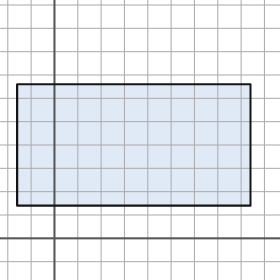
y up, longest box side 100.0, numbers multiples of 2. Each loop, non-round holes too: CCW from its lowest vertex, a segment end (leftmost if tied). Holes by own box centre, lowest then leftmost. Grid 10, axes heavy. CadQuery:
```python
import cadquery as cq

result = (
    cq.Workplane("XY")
    .moveTo(-16.0, 14.0)
    .lineTo(84.0, 14.0)
    .lineTo(84.0, 66.0)
    .lineTo(-16.0, 66.0)
    .close()
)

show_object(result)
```